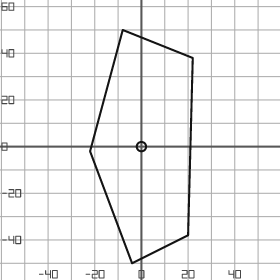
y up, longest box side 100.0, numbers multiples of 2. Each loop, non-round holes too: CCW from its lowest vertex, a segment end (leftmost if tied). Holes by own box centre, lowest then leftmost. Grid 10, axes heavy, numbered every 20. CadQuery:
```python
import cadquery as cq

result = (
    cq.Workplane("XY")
    .moveTo(-4.0, -50.0)
    .lineTo(20.0, -38.0)
    .lineTo(22.0, 38.0)
    .lineTo(-8.0, 50.0)
    .lineTo(-22.0, -2.0)
    .close()
    .moveTo(0.0, 0.0)
    .circle(2.0)
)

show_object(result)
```